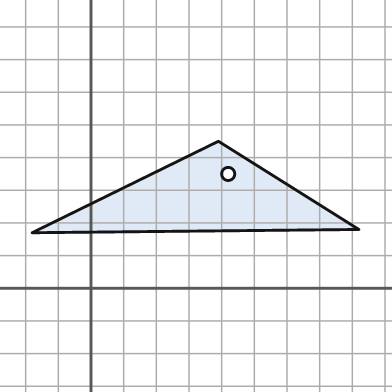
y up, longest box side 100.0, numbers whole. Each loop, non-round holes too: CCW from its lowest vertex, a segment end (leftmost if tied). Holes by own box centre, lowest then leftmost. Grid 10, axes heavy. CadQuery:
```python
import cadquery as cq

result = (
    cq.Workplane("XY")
    .moveTo(-18.0, 17.0)
    .lineTo(82.0, 18.0)
    .lineTo(39.0, 45.0)
    .close()
    .moveTo(42.0, 35.0)
    .circle(2.0)
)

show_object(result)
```